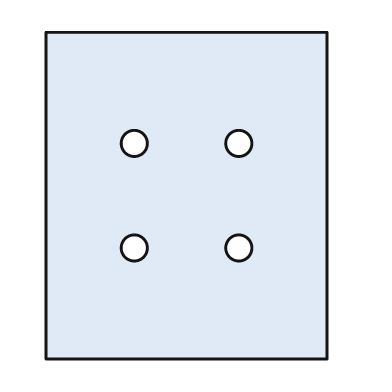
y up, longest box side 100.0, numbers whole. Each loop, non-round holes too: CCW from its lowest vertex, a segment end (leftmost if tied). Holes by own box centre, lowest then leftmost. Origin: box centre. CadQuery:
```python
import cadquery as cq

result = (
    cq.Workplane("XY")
    .moveTo(-43.0, -50.0)
    .lineTo(43.0, -50.0)
    .lineTo(43.0, 50.0)
    .lineTo(-43.0, 50.0)
    .close()
    .moveTo(-16.0, -16.0)
    .circle(4.0)
    .moveTo(16.0, -16.0)
    .circle(4.0)
    .moveTo(-16.0, 16.0)
    .circle(4.0)
    .moveTo(16.0, 16.0)
    .circle(4.0)
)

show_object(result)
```